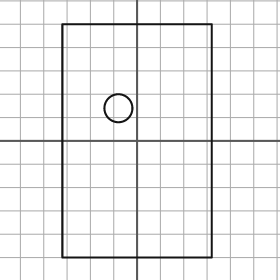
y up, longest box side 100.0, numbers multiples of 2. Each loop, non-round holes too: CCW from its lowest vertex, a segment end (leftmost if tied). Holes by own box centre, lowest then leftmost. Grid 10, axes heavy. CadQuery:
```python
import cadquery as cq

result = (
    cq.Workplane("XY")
    .moveTo(-32.0, -50.0)
    .lineTo(32.0, -50.0)
    .lineTo(32.0, 50.0)
    .lineTo(-32.0, 50.0)
    .close()
    .moveTo(-8.0, 14.0)
    .circle(6.0)
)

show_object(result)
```